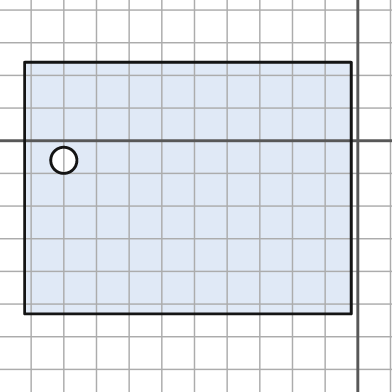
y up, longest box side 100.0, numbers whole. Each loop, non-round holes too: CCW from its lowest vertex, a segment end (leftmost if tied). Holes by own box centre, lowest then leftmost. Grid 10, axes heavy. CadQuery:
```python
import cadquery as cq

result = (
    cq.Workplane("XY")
    .moveTo(-102.0, -53.0)
    .lineTo(-2.0, -53.0)
    .lineTo(-2.0, 24.0)
    .lineTo(-102.0, 24.0)
    .close()
    .moveTo(-90.0, -6.0)
    .circle(4.0)
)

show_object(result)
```